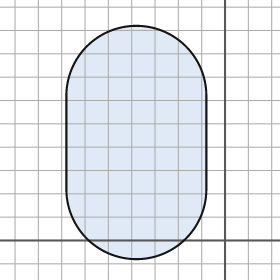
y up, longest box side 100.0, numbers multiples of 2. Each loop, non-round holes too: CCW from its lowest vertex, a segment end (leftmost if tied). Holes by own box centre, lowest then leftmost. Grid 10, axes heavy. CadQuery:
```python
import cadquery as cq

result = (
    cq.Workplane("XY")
    .moveTo(-68.0, 22.0)
    .threePointArc((-38.0, -8.0), (-8.0, 22.0))
    .lineTo(-8.0, 62.0)
    .threePointArc((-38.0, 92.0), (-68.0, 62.0))
    .close()
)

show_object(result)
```